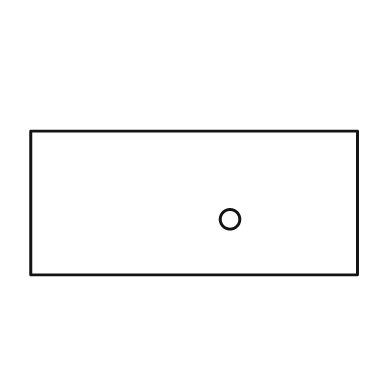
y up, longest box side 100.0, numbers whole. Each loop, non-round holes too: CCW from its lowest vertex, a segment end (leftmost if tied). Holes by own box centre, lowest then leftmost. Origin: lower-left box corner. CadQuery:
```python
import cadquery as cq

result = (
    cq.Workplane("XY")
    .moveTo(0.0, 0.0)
    .lineTo(100.0, 0.0)
    .lineTo(100.0, 44.0)
    .lineTo(0.0, 44.0)
    .close()
    .moveTo(61.0, 17.0)
    .circle(3.0)
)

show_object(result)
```